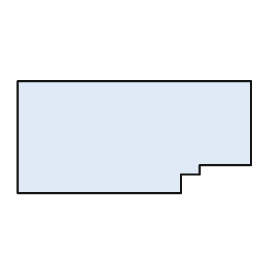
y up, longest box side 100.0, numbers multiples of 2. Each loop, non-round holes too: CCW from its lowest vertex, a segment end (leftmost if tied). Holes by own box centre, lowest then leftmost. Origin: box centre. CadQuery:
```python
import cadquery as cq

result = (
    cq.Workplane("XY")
    .moveTo(-50.0, -24.0)
    .lineTo(20.0, -24.0)
    .lineTo(20.0, -16.0)
    .lineTo(28.0, -16.0)
    .lineTo(28.0, -12.0)
    .lineTo(50.0, -12.0)
    .lineTo(50.0, 24.0)
    .lineTo(-50.0, 24.0)
    .close()
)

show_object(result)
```